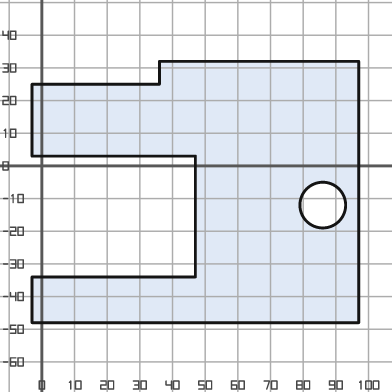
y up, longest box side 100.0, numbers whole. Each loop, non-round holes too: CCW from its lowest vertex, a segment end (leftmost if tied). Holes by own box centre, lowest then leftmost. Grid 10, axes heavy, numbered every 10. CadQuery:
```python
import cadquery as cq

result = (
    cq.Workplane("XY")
    .moveTo(-3.0, -48.0)
    .lineTo(97.0, -48.0)
    .lineTo(97.0, 32.0)
    .lineTo(36.0, 32.0)
    .lineTo(36.0, 25.0)
    .lineTo(-3.0, 25.0)
    .lineTo(-3.0, 3.0)
    .lineTo(47.0, 3.0)
    .lineTo(47.0, -34.0)
    .lineTo(-3.0, -34.0)
    .close()
    .moveTo(86.0, -12.0)
    .circle(7.0)
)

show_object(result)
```